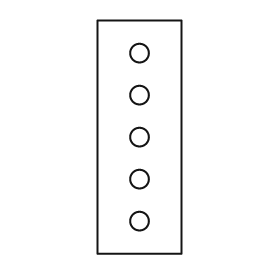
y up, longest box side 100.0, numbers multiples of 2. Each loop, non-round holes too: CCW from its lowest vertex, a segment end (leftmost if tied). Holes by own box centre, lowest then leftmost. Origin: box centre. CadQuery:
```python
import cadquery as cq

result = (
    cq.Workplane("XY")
    .moveTo(-18.0, -50.0)
    .lineTo(18.0, -50.0)
    .lineTo(18.0, 50.0)
    .lineTo(-18.0, 50.0)
    .close()
    .moveTo(0.0, -36.0)
    .circle(4.0)
    .moveTo(0.0, -18.0)
    .circle(4.0)
    .moveTo(0.0, 0.0)
    .circle(4.0)
    .moveTo(0.0, 18.0)
    .circle(4.0)
    .moveTo(0.0, 36.0)
    .circle(4.0)
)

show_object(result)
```